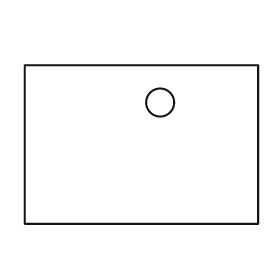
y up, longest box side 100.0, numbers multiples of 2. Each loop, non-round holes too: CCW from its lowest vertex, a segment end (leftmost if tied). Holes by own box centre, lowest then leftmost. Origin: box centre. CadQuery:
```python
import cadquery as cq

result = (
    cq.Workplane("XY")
    .moveTo(-50.0, -34.0)
    .lineTo(50.0, -34.0)
    .lineTo(50.0, 34.0)
    .lineTo(-50.0, 34.0)
    .close()
    .moveTo(8.0, 18.0)
    .circle(6.0)
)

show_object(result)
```